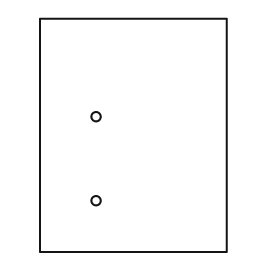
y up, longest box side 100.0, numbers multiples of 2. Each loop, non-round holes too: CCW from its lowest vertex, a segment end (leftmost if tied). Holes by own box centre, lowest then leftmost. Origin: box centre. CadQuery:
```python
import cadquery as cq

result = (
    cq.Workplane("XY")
    .moveTo(-40.0, -50.0)
    .lineTo(40.0, -50.0)
    .lineTo(40.0, 50.0)
    .lineTo(-40.0, 50.0)
    .close()
    .moveTo(-16.0, -28.0)
    .circle(2.0)
    .moveTo(-16.0, 8.0)
    .circle(2.0)
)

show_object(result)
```